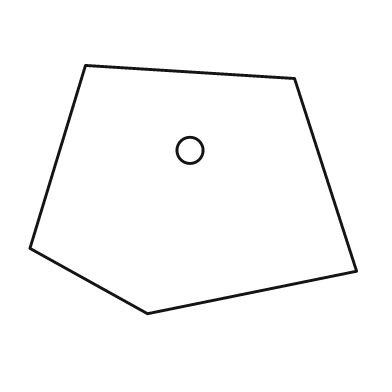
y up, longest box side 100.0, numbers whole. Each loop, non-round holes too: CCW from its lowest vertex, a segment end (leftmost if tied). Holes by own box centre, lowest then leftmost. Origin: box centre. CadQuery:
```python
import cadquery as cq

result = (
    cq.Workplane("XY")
    .moveTo(-14.0, -38.0)
    .lineTo(50.0, -25.0)
    .lineTo(31.0, 34.0)
    .lineTo(-33.0, 38.0)
    .lineTo(-50.0, -18.0)
    .close()
    .moveTo(-1.0, 12.0)
    .circle(4.0)
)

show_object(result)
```